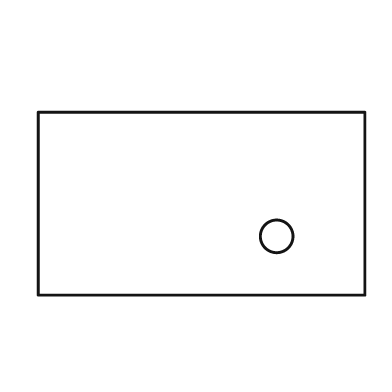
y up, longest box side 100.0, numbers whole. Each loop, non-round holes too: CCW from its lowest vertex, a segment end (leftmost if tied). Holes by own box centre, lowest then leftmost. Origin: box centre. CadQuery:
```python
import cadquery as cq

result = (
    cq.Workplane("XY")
    .moveTo(-50.0, -28.0)
    .lineTo(50.0, -28.0)
    .lineTo(50.0, 28.0)
    .lineTo(-50.0, 28.0)
    .close()
    .moveTo(23.0, -10.0)
    .circle(5.0)
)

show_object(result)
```